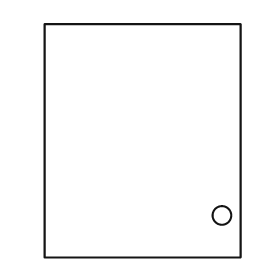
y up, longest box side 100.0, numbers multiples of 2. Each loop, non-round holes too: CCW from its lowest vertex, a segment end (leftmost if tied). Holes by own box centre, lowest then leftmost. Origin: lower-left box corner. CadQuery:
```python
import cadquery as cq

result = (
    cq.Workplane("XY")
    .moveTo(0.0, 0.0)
    .lineTo(84.0, 0.0)
    .lineTo(84.0, 100.0)
    .lineTo(0.0, 100.0)
    .close()
    .moveTo(76.0, 18.0)
    .circle(4.0)
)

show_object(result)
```